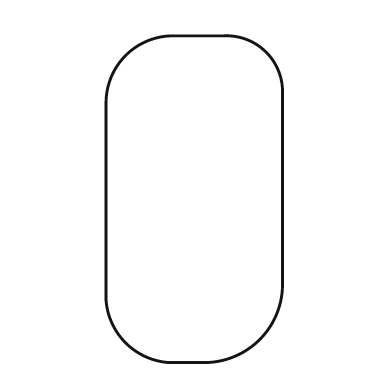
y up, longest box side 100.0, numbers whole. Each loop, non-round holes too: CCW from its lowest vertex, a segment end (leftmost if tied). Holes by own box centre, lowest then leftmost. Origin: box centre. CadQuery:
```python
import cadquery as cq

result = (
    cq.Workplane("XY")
    .moveTo(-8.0, -50.0)
    .lineTo(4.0, -50.0)
    .threePointArc((20.0, -43.0), (27.0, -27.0))
    .lineTo(27.0, 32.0)
    .threePointArc((22.0, 45.0), (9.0, 50.0))
    .lineTo(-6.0, 50.0)
    .threePointArc((-21.0, 44.0), (-27.0, 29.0))
    .lineTo(-27.0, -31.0)
    .threePointArc((-21.0, -44.0), (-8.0, -50.0))
    .close()
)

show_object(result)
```